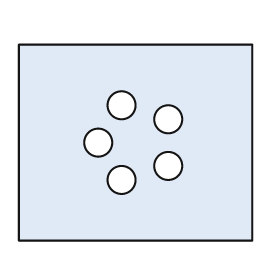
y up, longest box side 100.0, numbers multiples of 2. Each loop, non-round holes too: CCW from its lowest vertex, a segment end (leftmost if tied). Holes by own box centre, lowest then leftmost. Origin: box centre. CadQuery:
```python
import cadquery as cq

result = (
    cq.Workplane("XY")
    .moveTo(-50.0, -42.0)
    .lineTo(50.0, -42.0)
    .lineTo(50.0, 42.0)
    .lineTo(-50.0, 42.0)
    .close()
    .moveTo(-6.0, -16.0)
    .circle(6.0)
    .moveTo(14.0, -10.0)
    .circle(6.0)
    .moveTo(-16.0, 0.0)
    .circle(6.0)
    .moveTo(14.0, 10.0)
    .circle(6.0)
    .moveTo(-6.0, 16.0)
    .circle(6.0)
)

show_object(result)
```